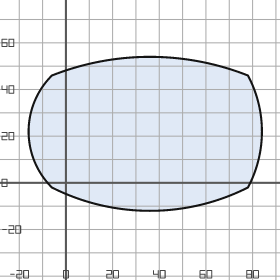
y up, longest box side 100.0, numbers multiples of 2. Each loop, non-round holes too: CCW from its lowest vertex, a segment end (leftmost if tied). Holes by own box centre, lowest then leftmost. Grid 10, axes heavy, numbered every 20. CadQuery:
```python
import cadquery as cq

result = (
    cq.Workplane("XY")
    .moveTo(-6.0, -2.0)
    .threePointArc((36.0, -12.0), (78.0, -2.0))
    .threePointArc((84.0, 22.0), (78.0, 46.0))
    .threePointArc((36.0, 54.0), (-6.0, 46.0))
    .threePointArc((-16.0, 22.0), (-6.0, -2.0))
    .close()
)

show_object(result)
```